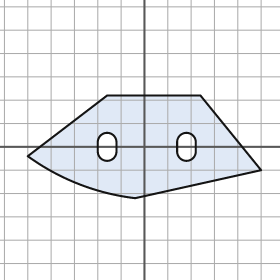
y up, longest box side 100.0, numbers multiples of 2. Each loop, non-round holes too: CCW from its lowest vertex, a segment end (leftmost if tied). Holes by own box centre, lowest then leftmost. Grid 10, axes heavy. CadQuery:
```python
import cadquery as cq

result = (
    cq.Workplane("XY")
    .moveTo(-4.0, -22.0)
    .lineTo(50.0, -10.0)
    .lineTo(24.0, 22.0)
    .lineTo(-16.0, 22.0)
    .lineTo(-50.0, -4.0)
    .threePointArc((-28.0, -16.0), (-4.0, -22.0))
    .close()
    .moveTo(-20.0, -2.0)
    .threePointArc((-16.0, -6.0), (-12.0, -2.0))
    .lineTo(-12.0, 2.0)
    .threePointArc((-16.0, 6.0), (-20.0, 2.0))
    .close()
    .moveTo(14.0, -2.0)
    .threePointArc((18.0, -6.0), (22.0, -2.0))
    .lineTo(22.0, 2.0)
    .threePointArc((18.0, 6.0), (14.0, 2.0))
    .close()
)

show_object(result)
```